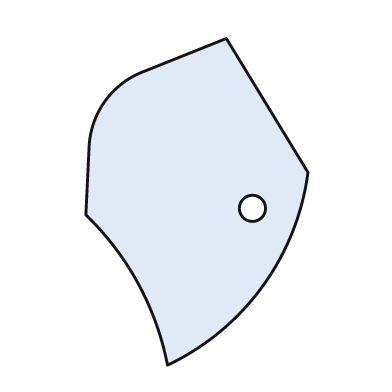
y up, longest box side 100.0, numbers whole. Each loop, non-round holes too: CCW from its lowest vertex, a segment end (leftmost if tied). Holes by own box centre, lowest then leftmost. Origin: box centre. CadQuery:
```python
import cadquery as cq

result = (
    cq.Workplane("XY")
    .moveTo(-9.0, -50.0)
    .threePointArc((20.0, -26.0), (34.0, 9.0))
    .lineTo(9.0, 50.0)
    .lineTo(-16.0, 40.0)
    .threePointArc((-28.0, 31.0), (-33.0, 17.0))
    .lineTo(-34.0, -4.0)
    .threePointArc((-18.0, -25.0), (-9.0, -50.0))
    .close()
    .moveTo(17.0, -2.0)
    .circle(4.0)
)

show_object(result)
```